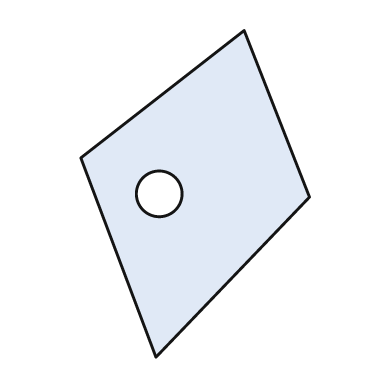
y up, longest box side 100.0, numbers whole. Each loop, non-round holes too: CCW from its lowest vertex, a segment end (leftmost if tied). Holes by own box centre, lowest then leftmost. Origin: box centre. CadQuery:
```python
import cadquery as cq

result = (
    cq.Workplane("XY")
    .moveTo(-12.0, -50.0)
    .lineTo(35.0, -1.0)
    .lineTo(15.0, 50.0)
    .lineTo(-35.0, 11.0)
    .close()
    .moveTo(-11.0, 0.0)
    .circle(7.0)
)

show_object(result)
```